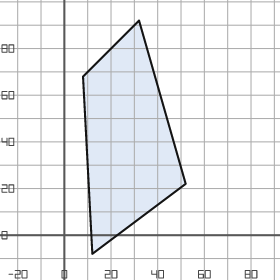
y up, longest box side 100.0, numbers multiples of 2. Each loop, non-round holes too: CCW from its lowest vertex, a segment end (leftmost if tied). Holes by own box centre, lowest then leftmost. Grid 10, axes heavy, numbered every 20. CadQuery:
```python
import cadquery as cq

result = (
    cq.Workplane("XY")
    .moveTo(12.0, -8.0)
    .lineTo(52.0, 22.0)
    .lineTo(32.0, 92.0)
    .lineTo(8.0, 68.0)
    .close()
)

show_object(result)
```